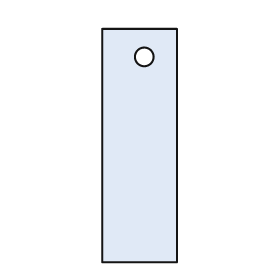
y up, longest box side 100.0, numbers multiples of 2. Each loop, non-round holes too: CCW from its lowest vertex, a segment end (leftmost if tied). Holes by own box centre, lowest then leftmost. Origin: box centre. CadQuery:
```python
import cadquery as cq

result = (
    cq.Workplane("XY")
    .moveTo(-16.0, -50.0)
    .lineTo(16.0, -50.0)
    .lineTo(16.0, 50.0)
    .lineTo(-16.0, 50.0)
    .close()
    .moveTo(2.0, 38.0)
    .circle(4.0)
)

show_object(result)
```